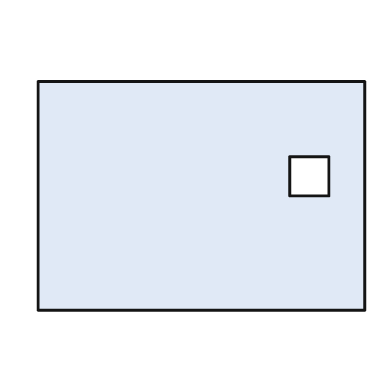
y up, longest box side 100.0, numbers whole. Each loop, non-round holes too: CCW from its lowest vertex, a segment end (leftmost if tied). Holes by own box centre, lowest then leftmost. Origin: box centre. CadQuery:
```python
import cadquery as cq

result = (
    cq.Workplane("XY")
    .moveTo(-50.0, -35.0)
    .lineTo(50.0, -35.0)
    .lineTo(50.0, 35.0)
    .lineTo(-50.0, 35.0)
    .close()
    .moveTo(27.0, 0.0)
    .lineTo(39.0, 0.0)
    .lineTo(39.0, 12.0)
    .lineTo(27.0, 12.0)
    .close()
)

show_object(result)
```